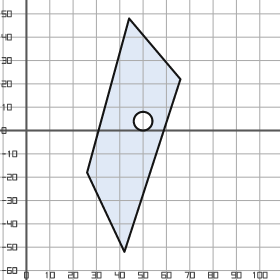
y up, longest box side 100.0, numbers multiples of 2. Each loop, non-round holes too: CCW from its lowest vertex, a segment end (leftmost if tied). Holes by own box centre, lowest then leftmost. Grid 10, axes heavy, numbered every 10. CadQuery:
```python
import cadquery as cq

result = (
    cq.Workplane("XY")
    .moveTo(42.0, -52.0)
    .lineTo(66.0, 22.0)
    .lineTo(44.0, 48.0)
    .lineTo(26.0, -18.0)
    .close()
    .moveTo(50.0, 4.0)
    .circle(4.0)
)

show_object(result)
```